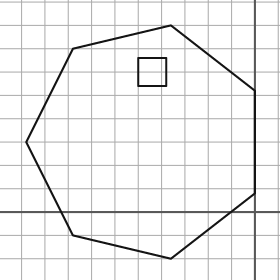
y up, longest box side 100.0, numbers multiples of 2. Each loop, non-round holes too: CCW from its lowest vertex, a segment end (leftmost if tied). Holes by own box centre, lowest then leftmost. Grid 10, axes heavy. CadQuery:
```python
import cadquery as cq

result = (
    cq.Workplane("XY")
    .moveTo(-36.0, -20.0)
    .lineTo(0.0, 8.0)
    .lineTo(0.0, 52.0)
    .lineTo(-36.0, 80.0)
    .lineTo(-78.0, 70.0)
    .lineTo(-98.0, 30.0)
    .lineTo(-78.0, -10.0)
    .close()
    .moveTo(-50.0, 54.0)
    .lineTo(-38.0, 54.0)
    .lineTo(-38.0, 66.0)
    .lineTo(-50.0, 66.0)
    .close()
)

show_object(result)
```